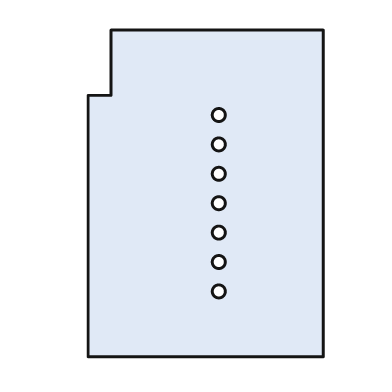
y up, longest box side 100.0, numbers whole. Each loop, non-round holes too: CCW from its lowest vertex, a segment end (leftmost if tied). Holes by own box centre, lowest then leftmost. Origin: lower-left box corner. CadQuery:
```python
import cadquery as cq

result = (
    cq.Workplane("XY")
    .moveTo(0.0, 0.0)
    .lineTo(72.0, 0.0)
    .lineTo(72.0, 100.0)
    .lineTo(7.0, 100.0)
    .lineTo(7.0, 80.0)
    .lineTo(0.0, 80.0)
    .close()
    .moveTo(40.0, 20.0)
    .circle(2.0)
    .moveTo(40.0, 29.0)
    .circle(2.0)
    .moveTo(40.0, 38.0)
    .circle(2.0)
    .moveTo(40.0, 47.0)
    .circle(2.0)
    .moveTo(40.0, 56.0)
    .circle(2.0)
    .moveTo(40.0, 65.0)
    .circle(2.0)
    .moveTo(40.0, 74.0)
    .circle(2.0)
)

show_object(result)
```